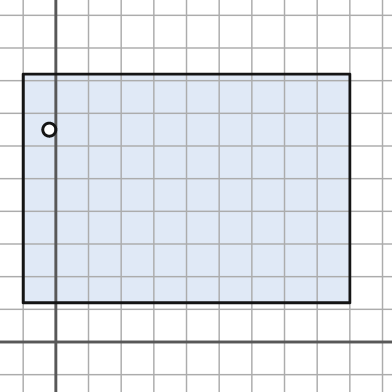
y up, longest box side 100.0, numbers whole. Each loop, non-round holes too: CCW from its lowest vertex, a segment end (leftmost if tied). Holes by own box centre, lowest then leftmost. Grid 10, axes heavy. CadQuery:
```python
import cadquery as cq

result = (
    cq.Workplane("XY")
    .moveTo(-10.0, 12.0)
    .lineTo(90.0, 12.0)
    .lineTo(90.0, 82.0)
    .lineTo(-10.0, 82.0)
    .close()
    .moveTo(-2.0, 65.0)
    .circle(2.0)
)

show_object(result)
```